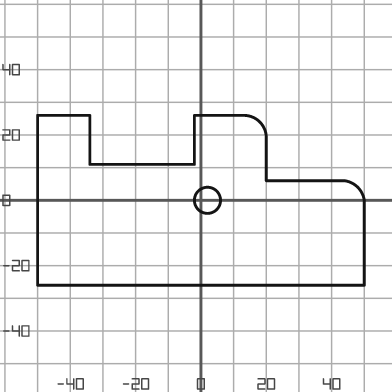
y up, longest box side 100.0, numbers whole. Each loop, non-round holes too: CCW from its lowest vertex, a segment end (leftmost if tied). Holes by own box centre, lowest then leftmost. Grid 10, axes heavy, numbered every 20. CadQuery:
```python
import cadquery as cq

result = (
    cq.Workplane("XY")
    .moveTo(-50.0, -26.0)
    .lineTo(50.0, -26.0)
    .lineTo(50.0, 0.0)
    .threePointArc((48.0, 4.0), (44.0, 6.0))
    .lineTo(20.0, 6.0)
    .lineTo(20.0, 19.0)
    .threePointArc((18.0, 24.0), (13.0, 26.0))
    .lineTo(-2.0, 26.0)
    .lineTo(-2.0, 11.0)
    .lineTo(-34.0, 11.0)
    .lineTo(-34.0, 26.0)
    .lineTo(-50.0, 26.0)
    .close()
    .moveTo(2.0, 0.0)
    .circle(4.0)
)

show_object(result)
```